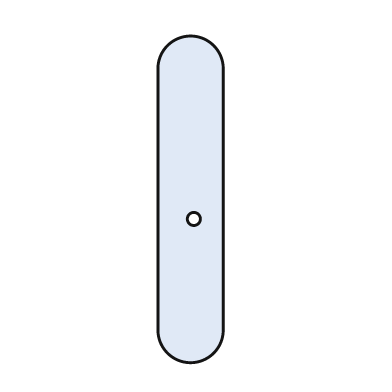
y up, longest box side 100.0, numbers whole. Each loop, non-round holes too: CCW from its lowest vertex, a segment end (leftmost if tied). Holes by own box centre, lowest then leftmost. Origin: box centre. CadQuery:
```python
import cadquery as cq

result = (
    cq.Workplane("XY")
    .moveTo(-10.0, -40.0)
    .threePointArc((0.0, -50.0), (10.0, -40.0))
    .lineTo(10.0, 40.0)
    .threePointArc((0.0, 50.0), (-10.0, 40.0))
    .close()
    .moveTo(1.0, -6.0)
    .circle(2.0)
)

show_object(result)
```